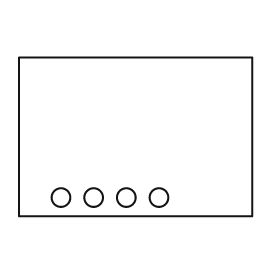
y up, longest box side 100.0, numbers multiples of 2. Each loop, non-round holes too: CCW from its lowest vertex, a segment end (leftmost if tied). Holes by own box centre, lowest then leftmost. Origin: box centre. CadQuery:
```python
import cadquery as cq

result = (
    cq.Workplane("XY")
    .moveTo(-50.0, -34.0)
    .lineTo(50.0, -34.0)
    .lineTo(50.0, 34.0)
    .lineTo(-50.0, 34.0)
    .close()
    .moveTo(-32.0, -26.0)
    .circle(4.0)
    .moveTo(-18.0, -26.0)
    .circle(4.0)
    .moveTo(-4.0, -26.0)
    .circle(4.0)
    .moveTo(10.0, -26.0)
    .circle(4.0)
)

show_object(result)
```